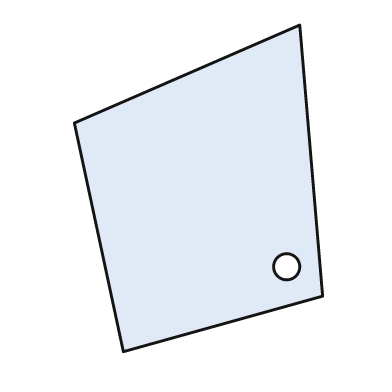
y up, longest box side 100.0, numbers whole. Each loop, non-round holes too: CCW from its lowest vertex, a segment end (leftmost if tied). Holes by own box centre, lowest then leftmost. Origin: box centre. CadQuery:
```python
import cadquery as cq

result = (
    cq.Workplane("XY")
    .moveTo(-23.0, -50.0)
    .lineTo(38.0, -33.0)
    .lineTo(31.0, 50.0)
    .lineTo(-38.0, 20.0)
    .close()
    .moveTo(27.0, -24.0)
    .circle(4.0)
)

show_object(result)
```